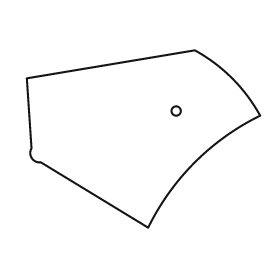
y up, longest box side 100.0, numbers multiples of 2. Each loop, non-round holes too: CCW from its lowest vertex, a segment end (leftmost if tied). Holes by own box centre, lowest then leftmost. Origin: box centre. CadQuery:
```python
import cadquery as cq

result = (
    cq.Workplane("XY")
    .moveTo(2.0, -38.0)
    .threePointArc((22.0, -10.0), (50.0, 10.0))
    .threePointArc((38.0, 26.0), (22.0, 38.0))
    .lineTo(-50.0, 26.0)
    .lineTo(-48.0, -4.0)
    .threePointArc((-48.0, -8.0), (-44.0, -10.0))
    .close()
    .moveTo(14.0, 12.0)
    .circle(2.0)
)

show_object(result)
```